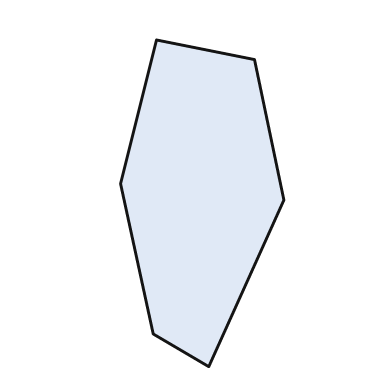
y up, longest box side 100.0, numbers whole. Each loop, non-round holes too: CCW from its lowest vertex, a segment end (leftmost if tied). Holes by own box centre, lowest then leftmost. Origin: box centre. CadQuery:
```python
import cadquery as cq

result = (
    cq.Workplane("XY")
    .moveTo(2.0, -50.0)
    .lineTo(25.0, 1.0)
    .lineTo(16.0, 44.0)
    .lineTo(-14.0, 50.0)
    .lineTo(-25.0, 6.0)
    .lineTo(-15.0, -40.0)
    .close()
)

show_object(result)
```